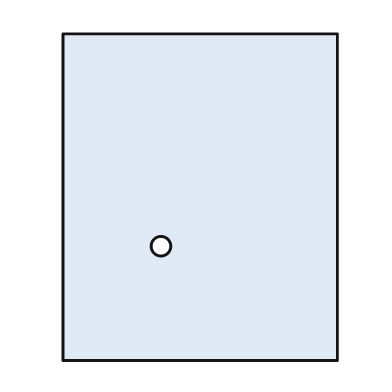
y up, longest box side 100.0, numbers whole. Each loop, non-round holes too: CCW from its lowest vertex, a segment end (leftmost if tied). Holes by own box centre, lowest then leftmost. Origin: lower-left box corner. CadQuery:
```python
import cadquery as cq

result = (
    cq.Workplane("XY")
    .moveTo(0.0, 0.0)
    .lineTo(84.0, 0.0)
    .lineTo(84.0, 100.0)
    .lineTo(0.0, 100.0)
    .close()
    .moveTo(30.0, 35.0)
    .circle(3.0)
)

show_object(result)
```